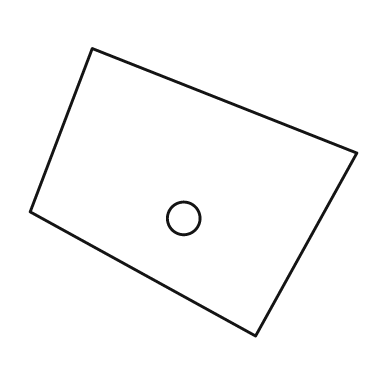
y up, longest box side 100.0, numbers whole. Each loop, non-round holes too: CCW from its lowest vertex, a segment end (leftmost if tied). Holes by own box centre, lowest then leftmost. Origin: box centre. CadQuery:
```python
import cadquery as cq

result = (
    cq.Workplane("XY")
    .moveTo(19.0, -44.0)
    .lineTo(50.0, 12.0)
    .lineTo(-31.0, 44.0)
    .lineTo(-50.0, -6.0)
    .close()
    .moveTo(-3.0, -8.0)
    .circle(5.0)
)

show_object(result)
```